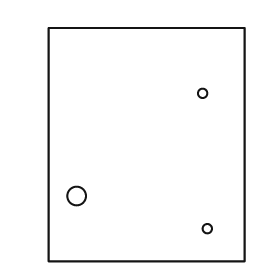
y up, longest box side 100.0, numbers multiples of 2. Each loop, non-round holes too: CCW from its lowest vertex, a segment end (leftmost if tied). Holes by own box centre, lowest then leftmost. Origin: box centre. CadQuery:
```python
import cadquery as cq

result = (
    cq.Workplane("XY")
    .moveTo(-42.0, -50.0)
    .lineTo(42.0, -50.0)
    .lineTo(42.0, 50.0)
    .lineTo(-42.0, 50.0)
    .close()
    .moveTo(26.0, -36.0)
    .circle(2.0)
    .moveTo(-30.0, -22.0)
    .circle(4.0)
    .moveTo(24.0, 22.0)
    .circle(2.0)
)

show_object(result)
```